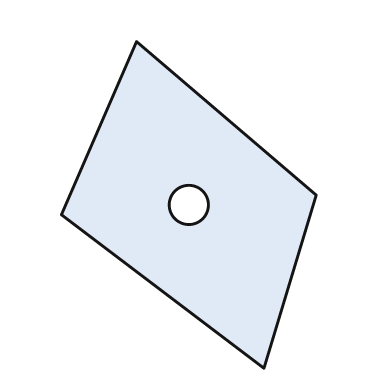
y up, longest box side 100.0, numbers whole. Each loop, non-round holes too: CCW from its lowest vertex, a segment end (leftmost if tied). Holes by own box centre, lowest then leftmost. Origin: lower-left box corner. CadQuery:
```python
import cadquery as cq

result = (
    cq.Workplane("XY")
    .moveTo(62.0, 0.0)
    .lineTo(78.0, 53.0)
    .lineTo(23.0, 100.0)
    .lineTo(0.0, 47.0)
    .close()
    .moveTo(39.0, 50.0)
    .circle(6.0)
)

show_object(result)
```